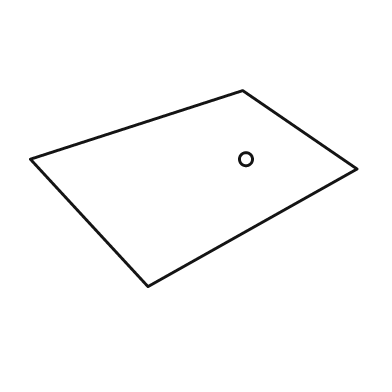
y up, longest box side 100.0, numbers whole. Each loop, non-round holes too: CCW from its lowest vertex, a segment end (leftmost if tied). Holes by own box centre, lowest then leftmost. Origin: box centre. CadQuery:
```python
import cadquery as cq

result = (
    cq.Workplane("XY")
    .moveTo(-14.0, -30.0)
    .lineTo(50.0, 6.0)
    .lineTo(15.0, 30.0)
    .lineTo(-50.0, 9.0)
    .close()
    .moveTo(16.0, 9.0)
    .circle(2.0)
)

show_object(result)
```